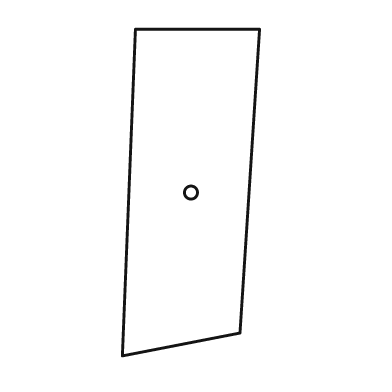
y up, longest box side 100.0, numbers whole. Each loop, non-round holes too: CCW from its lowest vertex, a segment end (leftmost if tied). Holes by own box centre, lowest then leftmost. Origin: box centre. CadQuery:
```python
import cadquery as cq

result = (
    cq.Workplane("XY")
    .moveTo(-21.0, -50.0)
    .lineTo(15.0, -43.0)
    .lineTo(21.0, 50.0)
    .lineTo(-17.0, 50.0)
    .close()
    .moveTo(0.0, 0.0)
    .circle(2.0)
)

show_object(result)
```